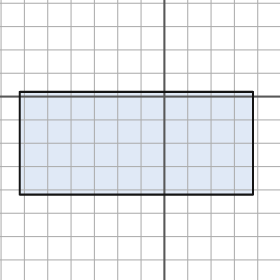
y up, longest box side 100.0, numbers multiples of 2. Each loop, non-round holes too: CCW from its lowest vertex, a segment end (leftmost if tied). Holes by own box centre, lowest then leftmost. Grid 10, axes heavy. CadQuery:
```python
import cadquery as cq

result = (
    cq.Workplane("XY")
    .moveTo(-62.0, -42.0)
    .lineTo(38.0, -42.0)
    .lineTo(38.0, 2.0)
    .lineTo(-62.0, 2.0)
    .close()
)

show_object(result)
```